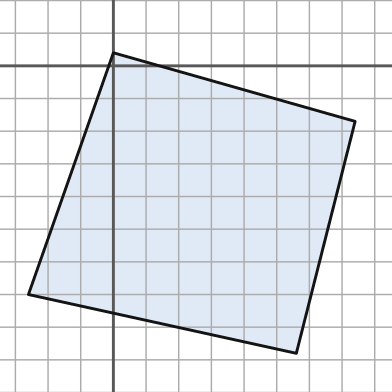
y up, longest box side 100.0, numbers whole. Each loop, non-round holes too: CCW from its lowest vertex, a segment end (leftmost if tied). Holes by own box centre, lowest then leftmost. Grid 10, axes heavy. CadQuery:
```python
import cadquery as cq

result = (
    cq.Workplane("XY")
    .moveTo(56.0, -88.0)
    .lineTo(74.0, -17.0)
    .lineTo(0.0, 4.0)
    .lineTo(-26.0, -70.0)
    .close()
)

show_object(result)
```